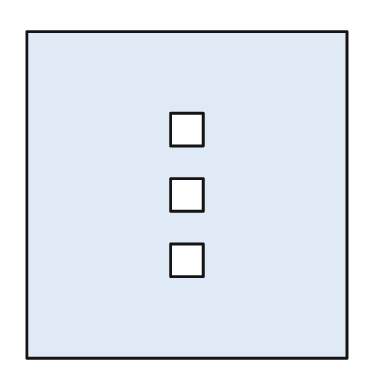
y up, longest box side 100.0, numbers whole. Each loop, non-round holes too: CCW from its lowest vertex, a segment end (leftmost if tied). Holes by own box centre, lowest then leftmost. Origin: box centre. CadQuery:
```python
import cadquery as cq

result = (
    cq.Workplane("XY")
    .moveTo(-49.0, -50.0)
    .lineTo(49.0, -50.0)
    .lineTo(49.0, 50.0)
    .lineTo(-49.0, 50.0)
    .close()
    .moveTo(-5.0, -25.0)
    .lineTo(5.0, -25.0)
    .lineTo(5.0, -15.0)
    .lineTo(-5.0, -15.0)
    .close()
    .moveTo(-5.0, -5.0)
    .lineTo(5.0, -5.0)
    .lineTo(5.0, 5.0)
    .lineTo(-5.0, 5.0)
    .close()
    .moveTo(-5.0, 15.0)
    .lineTo(5.0, 15.0)
    .lineTo(5.0, 25.0)
    .lineTo(-5.0, 25.0)
    .close()
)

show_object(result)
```